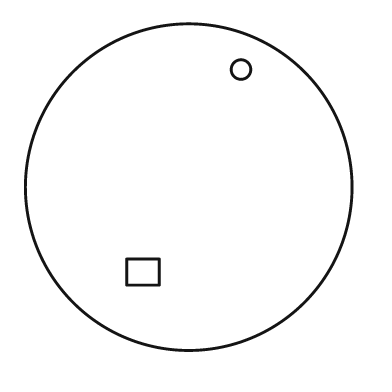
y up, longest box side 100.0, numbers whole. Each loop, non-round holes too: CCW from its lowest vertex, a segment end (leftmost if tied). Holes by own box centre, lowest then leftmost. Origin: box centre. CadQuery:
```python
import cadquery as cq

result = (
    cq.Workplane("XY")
    .moveTo(0.0, 0.0)
    .circle(50.0)
    .moveTo(-19.0, -30.0)
    .lineTo(-9.0, -30.0)
    .lineTo(-9.0, -22.0)
    .lineTo(-19.0, -22.0)
    .close()
    .moveTo(16.0, 36.0)
    .circle(3.0)
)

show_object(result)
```